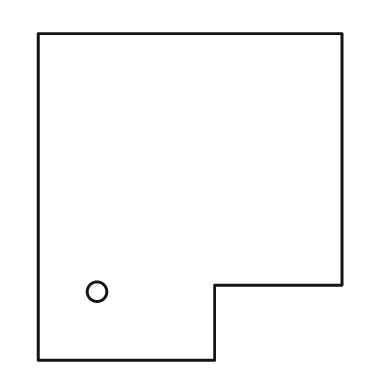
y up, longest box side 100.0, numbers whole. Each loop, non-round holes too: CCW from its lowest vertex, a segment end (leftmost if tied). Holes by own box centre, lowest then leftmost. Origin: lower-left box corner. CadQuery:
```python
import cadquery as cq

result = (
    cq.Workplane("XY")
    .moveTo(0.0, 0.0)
    .lineTo(54.0, 0.0)
    .lineTo(54.0, 23.0)
    .lineTo(93.0, 23.0)
    .lineTo(93.0, 100.0)
    .lineTo(0.0, 100.0)
    .close()
    .moveTo(18.0, 21.0)
    .circle(3.0)
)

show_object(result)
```